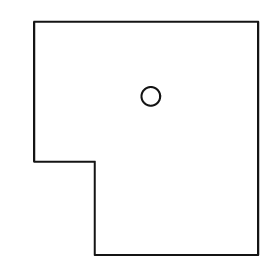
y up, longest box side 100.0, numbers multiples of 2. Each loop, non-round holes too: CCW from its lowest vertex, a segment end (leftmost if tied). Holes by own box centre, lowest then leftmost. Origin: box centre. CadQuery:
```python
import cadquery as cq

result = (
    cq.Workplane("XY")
    .moveTo(-22.0, -50.0)
    .lineTo(48.0, -50.0)
    .lineTo(48.0, 50.0)
    .lineTo(-48.0, 50.0)
    .lineTo(-48.0, -10.0)
    .lineTo(-22.0, -10.0)
    .close()
    .moveTo(2.0, 18.0)
    .circle(4.0)
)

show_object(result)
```